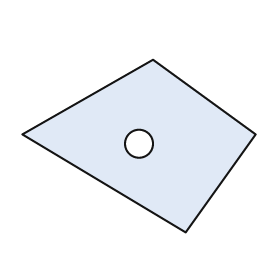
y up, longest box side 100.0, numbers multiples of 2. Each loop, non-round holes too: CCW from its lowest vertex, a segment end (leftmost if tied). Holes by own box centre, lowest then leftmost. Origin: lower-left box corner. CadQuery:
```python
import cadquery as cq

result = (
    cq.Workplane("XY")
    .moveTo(70.0, 0.0)
    .lineTo(100.0, 42.0)
    .lineTo(56.0, 74.0)
    .lineTo(0.0, 42.0)
    .close()
    .moveTo(50.0, 38.0)
    .circle(6.0)
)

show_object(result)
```